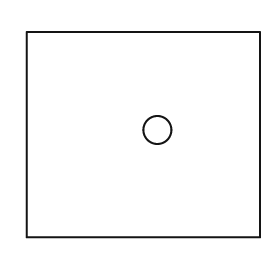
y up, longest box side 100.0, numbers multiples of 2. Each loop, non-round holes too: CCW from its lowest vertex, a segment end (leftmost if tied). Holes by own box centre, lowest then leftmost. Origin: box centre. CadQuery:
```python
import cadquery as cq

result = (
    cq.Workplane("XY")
    .moveTo(-50.0, -44.0)
    .lineTo(50.0, -44.0)
    .lineTo(50.0, 44.0)
    .lineTo(-50.0, 44.0)
    .close()
    .moveTo(6.0, 2.0)
    .circle(6.0)
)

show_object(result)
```